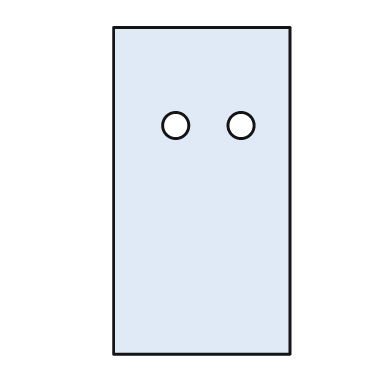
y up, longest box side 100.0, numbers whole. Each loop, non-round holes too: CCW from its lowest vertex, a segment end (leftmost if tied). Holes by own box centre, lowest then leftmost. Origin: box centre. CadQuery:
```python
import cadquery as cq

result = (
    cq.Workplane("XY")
    .moveTo(-27.0, -50.0)
    .lineTo(27.0, -50.0)
    .lineTo(27.0, 50.0)
    .lineTo(-27.0, 50.0)
    .close()
    .moveTo(-8.0, 20.0)
    .circle(4.0)
    .moveTo(12.0, 20.0)
    .circle(4.0)
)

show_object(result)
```